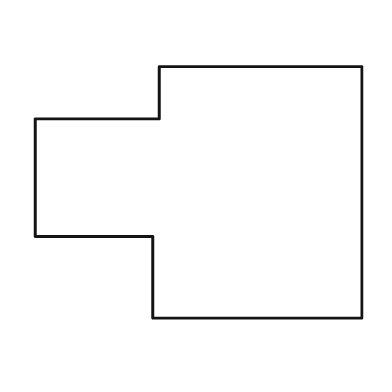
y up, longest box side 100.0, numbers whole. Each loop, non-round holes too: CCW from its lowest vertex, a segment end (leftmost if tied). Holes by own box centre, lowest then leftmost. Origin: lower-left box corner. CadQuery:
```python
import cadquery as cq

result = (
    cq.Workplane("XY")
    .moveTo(36.0, 0.0)
    .lineTo(100.0, 0.0)
    .lineTo(100.0, 77.0)
    .lineTo(38.0, 77.0)
    .lineTo(38.0, 61.0)
    .lineTo(0.0, 61.0)
    .lineTo(0.0, 25.0)
    .lineTo(36.0, 25.0)
    .close()
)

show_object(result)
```